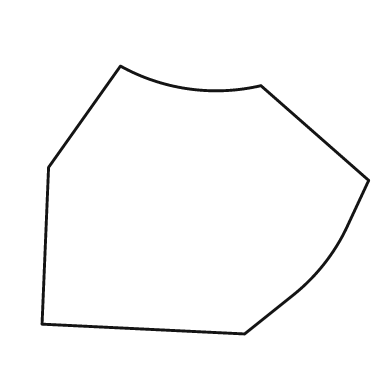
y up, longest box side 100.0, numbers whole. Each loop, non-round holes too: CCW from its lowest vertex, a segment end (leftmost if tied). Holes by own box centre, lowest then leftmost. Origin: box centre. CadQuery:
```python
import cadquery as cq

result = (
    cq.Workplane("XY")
    .moveTo(12.0, -41.0)
    .lineTo(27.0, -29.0)
    .threePointArc((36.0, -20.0), (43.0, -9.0))
    .lineTo(50.0, 6.0)
    .lineTo(17.0, 35.0)
    .threePointArc((-5.0, 34.0), (-26.0, 41.0))
    .lineTo(-48.0, 10.0)
    .lineTo(-50.0, -38.0)
    .close()
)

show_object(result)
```